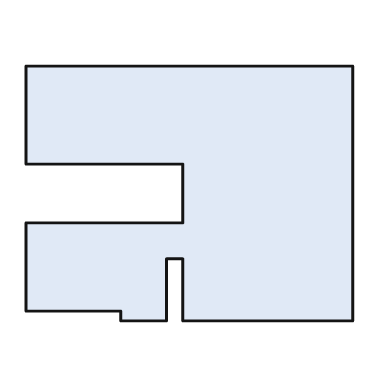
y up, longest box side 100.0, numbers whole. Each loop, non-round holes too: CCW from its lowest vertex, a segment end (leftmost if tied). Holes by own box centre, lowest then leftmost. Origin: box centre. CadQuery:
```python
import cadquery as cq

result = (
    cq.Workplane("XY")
    .moveTo(-21.0, -39.0)
    .lineTo(-7.0, -39.0)
    .lineTo(-7.0, -20.0)
    .lineTo(-2.0, -20.0)
    .lineTo(-2.0, -39.0)
    .lineTo(50.0, -39.0)
    .lineTo(50.0, 39.0)
    .lineTo(-50.0, 39.0)
    .lineTo(-50.0, 9.0)
    .lineTo(-2.0, 9.0)
    .lineTo(-2.0, -9.0)
    .lineTo(-50.0, -9.0)
    .lineTo(-50.0, -36.0)
    .lineTo(-21.0, -36.0)
    .close()
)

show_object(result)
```